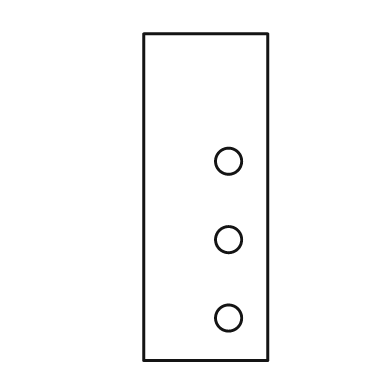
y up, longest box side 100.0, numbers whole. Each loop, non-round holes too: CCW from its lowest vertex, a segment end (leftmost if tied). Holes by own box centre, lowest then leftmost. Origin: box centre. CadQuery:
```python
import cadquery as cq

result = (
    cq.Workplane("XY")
    .moveTo(-19.0, -50.0)
    .lineTo(19.0, -50.0)
    .lineTo(19.0, 50.0)
    .lineTo(-19.0, 50.0)
    .close()
    .moveTo(7.0, -37.0)
    .circle(4.0)
    .moveTo(7.0, -13.0)
    .circle(4.0)
    .moveTo(7.0, 11.0)
    .circle(4.0)
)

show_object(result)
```